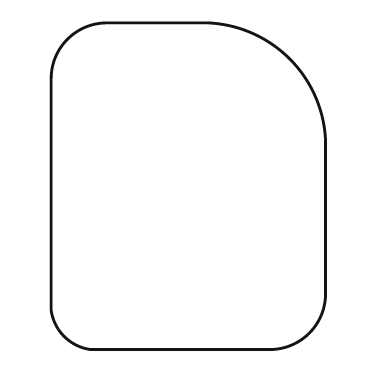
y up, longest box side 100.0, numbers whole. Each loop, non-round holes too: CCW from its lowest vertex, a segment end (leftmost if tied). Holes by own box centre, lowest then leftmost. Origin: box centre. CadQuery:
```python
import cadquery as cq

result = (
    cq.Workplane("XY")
    .moveTo(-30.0, -50.0)
    .lineTo(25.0, -50.0)
    .threePointArc((37.0, -45.0), (42.0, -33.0))
    .lineTo(42.0, 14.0)
    .threePointArc((31.0, 39.0), (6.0, 50.0))
    .lineTo(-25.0, 50.0)
    .threePointArc((-37.0, 45.0), (-42.0, 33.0))
    .lineTo(-42.0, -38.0)
    .threePointArc((-38.0, -46.0), (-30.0, -50.0))
    .close()
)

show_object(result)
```